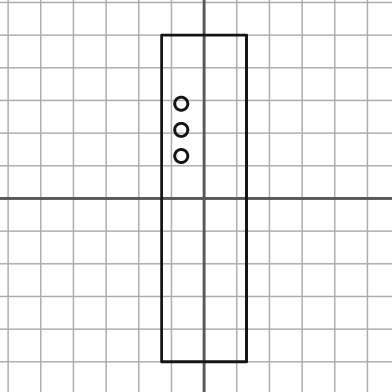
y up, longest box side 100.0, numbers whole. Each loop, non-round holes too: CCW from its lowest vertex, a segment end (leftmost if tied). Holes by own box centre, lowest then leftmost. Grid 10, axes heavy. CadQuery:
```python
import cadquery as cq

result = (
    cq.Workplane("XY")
    .moveTo(-13.0, -50.0)
    .lineTo(13.0, -50.0)
    .lineTo(13.0, 50.0)
    .lineTo(-13.0, 50.0)
    .close()
    .moveTo(-7.0, 13.0)
    .circle(2.0)
    .moveTo(-7.0, 21.0)
    .circle(2.0)
    .moveTo(-7.0, 29.0)
    .circle(2.0)
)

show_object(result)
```